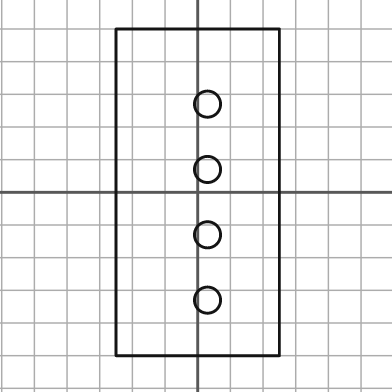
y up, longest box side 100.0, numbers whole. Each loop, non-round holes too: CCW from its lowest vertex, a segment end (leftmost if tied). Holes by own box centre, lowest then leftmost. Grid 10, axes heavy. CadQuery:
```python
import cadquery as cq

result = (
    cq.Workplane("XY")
    .moveTo(-25.0, -50.0)
    .lineTo(25.0, -50.0)
    .lineTo(25.0, 50.0)
    .lineTo(-25.0, 50.0)
    .close()
    .moveTo(3.0, -33.0)
    .circle(4.0)
    .moveTo(3.0, -13.0)
    .circle(4.0)
    .moveTo(3.0, 7.0)
    .circle(4.0)
    .moveTo(3.0, 27.0)
    .circle(4.0)
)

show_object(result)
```